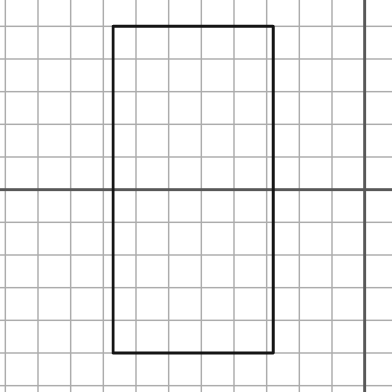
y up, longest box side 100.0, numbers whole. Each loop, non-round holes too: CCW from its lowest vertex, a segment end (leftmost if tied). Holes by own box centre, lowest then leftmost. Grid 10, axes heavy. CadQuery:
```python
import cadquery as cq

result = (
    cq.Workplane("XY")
    .moveTo(-77.0, -50.0)
    .lineTo(-28.0, -50.0)
    .lineTo(-28.0, 50.0)
    .lineTo(-77.0, 50.0)
    .close()
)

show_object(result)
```